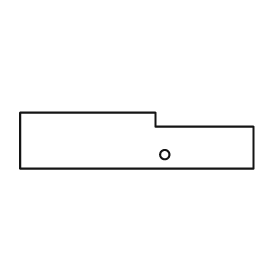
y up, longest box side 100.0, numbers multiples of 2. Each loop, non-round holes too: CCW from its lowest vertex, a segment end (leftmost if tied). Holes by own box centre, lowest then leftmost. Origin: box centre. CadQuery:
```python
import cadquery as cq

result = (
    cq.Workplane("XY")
    .moveTo(-50.0, -12.0)
    .lineTo(50.0, -12.0)
    .lineTo(50.0, 6.0)
    .lineTo(8.0, 6.0)
    .lineTo(8.0, 12.0)
    .lineTo(-50.0, 12.0)
    .close()
    .moveTo(12.0, -6.0)
    .circle(2.0)
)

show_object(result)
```